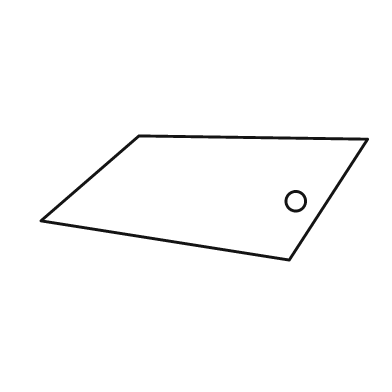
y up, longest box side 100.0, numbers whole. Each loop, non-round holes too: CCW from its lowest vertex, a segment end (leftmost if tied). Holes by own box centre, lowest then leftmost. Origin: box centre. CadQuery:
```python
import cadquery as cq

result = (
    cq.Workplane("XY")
    .moveTo(26.0, -19.0)
    .lineTo(50.0, 18.0)
    .lineTo(-20.0, 19.0)
    .lineTo(-50.0, -7.0)
    .close()
    .moveTo(28.0, -1.0)
    .circle(3.0)
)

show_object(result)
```